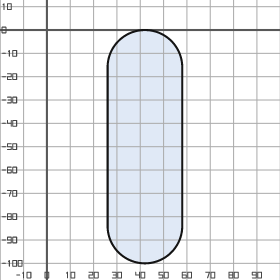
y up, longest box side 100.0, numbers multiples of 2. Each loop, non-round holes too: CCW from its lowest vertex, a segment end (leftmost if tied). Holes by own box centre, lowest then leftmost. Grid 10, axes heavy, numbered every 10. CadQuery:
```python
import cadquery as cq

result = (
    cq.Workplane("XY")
    .moveTo(26.0, -84.0)
    .threePointArc((42.0, -100.0), (58.0, -84.0))
    .lineTo(58.0, -16.0)
    .threePointArc((42.0, 0.0), (26.0, -16.0))
    .close()
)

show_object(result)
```